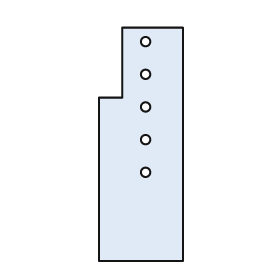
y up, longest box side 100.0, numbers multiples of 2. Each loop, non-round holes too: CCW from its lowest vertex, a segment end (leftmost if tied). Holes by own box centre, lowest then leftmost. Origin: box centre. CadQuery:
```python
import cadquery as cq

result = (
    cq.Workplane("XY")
    .moveTo(-18.0, -50.0)
    .lineTo(18.0, -50.0)
    .lineTo(18.0, 50.0)
    .lineTo(-8.0, 50.0)
    .lineTo(-8.0, 20.0)
    .lineTo(-18.0, 20.0)
    .close()
    .moveTo(2.0, -12.0)
    .circle(2.0)
    .moveTo(2.0, 2.0)
    .circle(2.0)
    .moveTo(2.0, 16.0)
    .circle(2.0)
    .moveTo(2.0, 30.0)
    .circle(2.0)
    .moveTo(2.0, 44.0)
    .circle(2.0)
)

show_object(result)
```